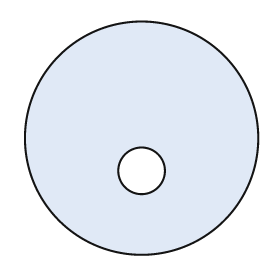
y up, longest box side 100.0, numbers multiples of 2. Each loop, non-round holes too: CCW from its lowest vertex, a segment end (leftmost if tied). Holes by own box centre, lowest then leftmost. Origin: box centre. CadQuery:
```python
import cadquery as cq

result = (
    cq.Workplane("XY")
    .moveTo(0.0, 0.0)
    .circle(50.0)
    .moveTo(0.0, -14.0)
    .circle(10.0)
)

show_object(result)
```